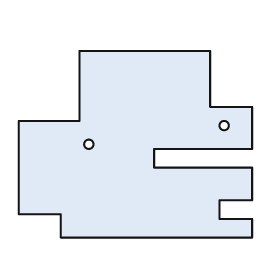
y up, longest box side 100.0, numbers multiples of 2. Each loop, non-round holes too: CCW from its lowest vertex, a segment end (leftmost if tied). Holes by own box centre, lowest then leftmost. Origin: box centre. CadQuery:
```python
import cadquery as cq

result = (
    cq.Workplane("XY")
    .moveTo(-32.0, -40.0)
    .lineTo(50.0, -40.0)
    .lineTo(50.0, -32.0)
    .lineTo(36.0, -32.0)
    .lineTo(36.0, -24.0)
    .lineTo(50.0, -24.0)
    .lineTo(50.0, -10.0)
    .lineTo(8.0, -10.0)
    .lineTo(8.0, -2.0)
    .lineTo(50.0, -2.0)
    .lineTo(50.0, 16.0)
    .lineTo(32.0, 16.0)
    .lineTo(32.0, 40.0)
    .lineTo(-24.0, 40.0)
    .lineTo(-24.0, 10.0)
    .lineTo(-50.0, 10.0)
    .lineTo(-50.0, -30.0)
    .lineTo(-32.0, -30.0)
    .close()
    .moveTo(-20.0, 0.0)
    .circle(2.0)
    .moveTo(38.0, 8.0)
    .circle(2.0)
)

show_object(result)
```